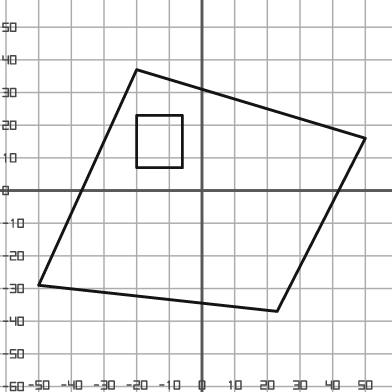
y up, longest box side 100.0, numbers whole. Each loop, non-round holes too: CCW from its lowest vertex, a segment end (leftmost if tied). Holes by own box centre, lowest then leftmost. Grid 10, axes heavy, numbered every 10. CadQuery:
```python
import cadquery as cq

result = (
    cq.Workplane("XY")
    .moveTo(23.0, -37.0)
    .lineTo(50.0, 16.0)
    .lineTo(-20.0, 37.0)
    .lineTo(-50.0, -29.0)
    .close()
    .moveTo(-20.0, 7.0)
    .lineTo(-6.0, 7.0)
    .lineTo(-6.0, 23.0)
    .lineTo(-20.0, 23.0)
    .close()
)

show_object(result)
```